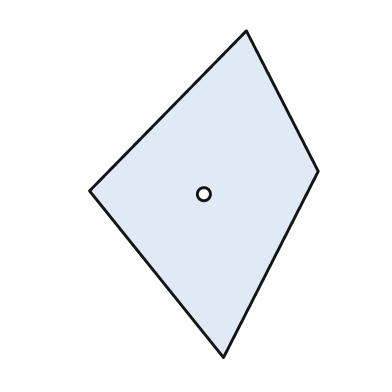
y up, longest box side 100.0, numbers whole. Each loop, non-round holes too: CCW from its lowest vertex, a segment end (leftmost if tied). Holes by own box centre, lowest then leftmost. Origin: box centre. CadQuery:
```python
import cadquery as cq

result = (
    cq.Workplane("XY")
    .moveTo(6.0, -50.0)
    .lineTo(35.0, 7.0)
    .lineTo(13.0, 50.0)
    .lineTo(-35.0, 1.0)
    .close()
    .moveTo(0.0, 0.0)
    .circle(2.0)
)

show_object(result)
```